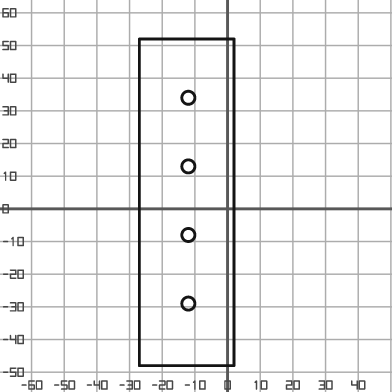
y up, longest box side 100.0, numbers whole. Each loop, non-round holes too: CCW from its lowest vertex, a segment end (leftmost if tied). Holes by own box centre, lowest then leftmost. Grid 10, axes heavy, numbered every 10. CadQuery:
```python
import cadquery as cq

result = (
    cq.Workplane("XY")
    .moveTo(-27.0, -48.0)
    .lineTo(2.0, -48.0)
    .lineTo(2.0, 52.0)
    .lineTo(-27.0, 52.0)
    .close()
    .moveTo(-12.0, -29.0)
    .circle(2.0)
    .moveTo(-12.0, -8.0)
    .circle(2.0)
    .moveTo(-12.0, 13.0)
    .circle(2.0)
    .moveTo(-12.0, 34.0)
    .circle(2.0)
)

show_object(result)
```